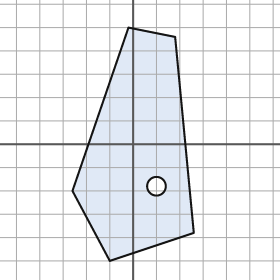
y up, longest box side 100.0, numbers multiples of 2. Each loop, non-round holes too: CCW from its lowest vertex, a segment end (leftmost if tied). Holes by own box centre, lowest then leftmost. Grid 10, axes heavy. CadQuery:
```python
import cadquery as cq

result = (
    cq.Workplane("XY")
    .moveTo(-10.0, -50.0)
    .lineTo(26.0, -38.0)
    .lineTo(18.0, 46.0)
    .lineTo(-2.0, 50.0)
    .lineTo(-26.0, -20.0)
    .close()
    .moveTo(10.0, -18.0)
    .circle(4.0)
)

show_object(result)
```